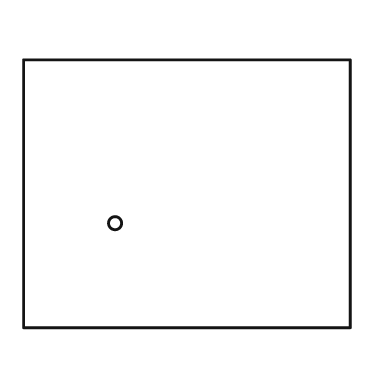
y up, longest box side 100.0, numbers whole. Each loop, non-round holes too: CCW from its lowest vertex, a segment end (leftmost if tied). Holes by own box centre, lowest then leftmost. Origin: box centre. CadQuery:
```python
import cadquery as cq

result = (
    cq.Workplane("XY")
    .moveTo(-50.0, -41.0)
    .lineTo(50.0, -41.0)
    .lineTo(50.0, 41.0)
    .lineTo(-50.0, 41.0)
    .close()
    .moveTo(-22.0, -9.0)
    .circle(2.0)
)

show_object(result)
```